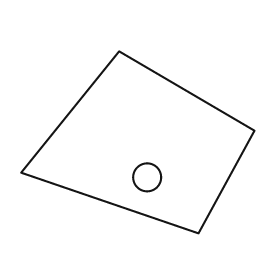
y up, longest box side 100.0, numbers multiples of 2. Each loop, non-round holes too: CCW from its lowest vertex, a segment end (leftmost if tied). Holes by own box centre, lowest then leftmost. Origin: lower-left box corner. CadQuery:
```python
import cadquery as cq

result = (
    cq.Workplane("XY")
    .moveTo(76.0, 0.0)
    .lineTo(100.0, 44.0)
    .lineTo(42.0, 78.0)
    .lineTo(0.0, 26.0)
    .close()
    .moveTo(54.0, 24.0)
    .circle(6.0)
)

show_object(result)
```